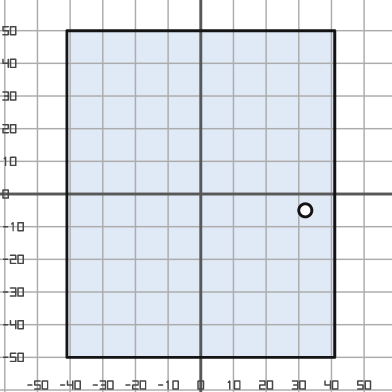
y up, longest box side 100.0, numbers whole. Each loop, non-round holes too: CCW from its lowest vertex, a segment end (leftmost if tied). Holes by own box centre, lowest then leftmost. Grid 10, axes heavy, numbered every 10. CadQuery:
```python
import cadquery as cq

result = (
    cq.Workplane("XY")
    .moveTo(-41.0, -50.0)
    .lineTo(41.0, -50.0)
    .lineTo(41.0, 50.0)
    .lineTo(-41.0, 50.0)
    .close()
    .moveTo(32.0, -5.0)
    .circle(2.0)
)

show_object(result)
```